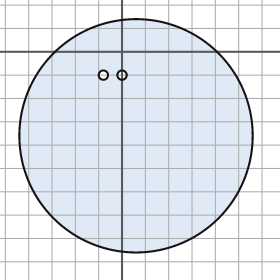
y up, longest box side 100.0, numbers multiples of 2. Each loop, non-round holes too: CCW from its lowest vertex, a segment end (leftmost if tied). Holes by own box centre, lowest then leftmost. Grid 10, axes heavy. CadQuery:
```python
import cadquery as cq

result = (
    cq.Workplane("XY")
    .moveTo(6.0, -36.0)
    .circle(50.0)
    .moveTo(-8.0, -10.0)
    .circle(2.0)
    .moveTo(0.0, -10.0)
    .circle(2.0)
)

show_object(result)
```